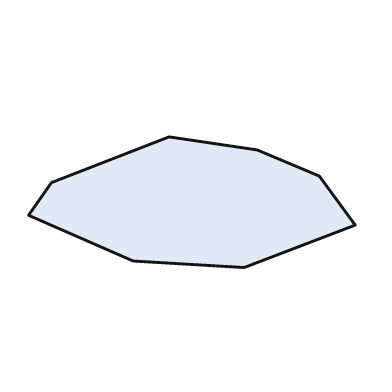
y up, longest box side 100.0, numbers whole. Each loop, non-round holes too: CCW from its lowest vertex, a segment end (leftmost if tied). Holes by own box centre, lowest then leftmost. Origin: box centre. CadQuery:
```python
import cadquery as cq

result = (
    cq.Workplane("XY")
    .moveTo(16.0, -20.0)
    .lineTo(50.0, -7.0)
    .lineTo(39.0, 8.0)
    .lineTo(20.0, 16.0)
    .lineTo(-7.0, 20.0)
    .lineTo(-43.0, 6.0)
    .lineTo(-50.0, -4.0)
    .lineTo(-18.0, -18.0)
    .close()
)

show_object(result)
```